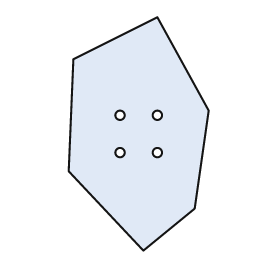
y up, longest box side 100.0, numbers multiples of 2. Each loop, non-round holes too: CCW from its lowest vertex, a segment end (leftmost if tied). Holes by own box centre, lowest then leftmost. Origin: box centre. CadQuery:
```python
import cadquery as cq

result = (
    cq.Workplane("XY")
    .moveTo(2.0, -50.0)
    .lineTo(24.0, -32.0)
    .lineTo(30.0, 10.0)
    .lineTo(8.0, 50.0)
    .lineTo(-28.0, 32.0)
    .lineTo(-30.0, -16.0)
    .close()
    .moveTo(-8.0, -8.0)
    .circle(2.0)
    .moveTo(8.0, -8.0)
    .circle(2.0)
    .moveTo(-8.0, 8.0)
    .circle(2.0)
    .moveTo(8.0, 8.0)
    .circle(2.0)
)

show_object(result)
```